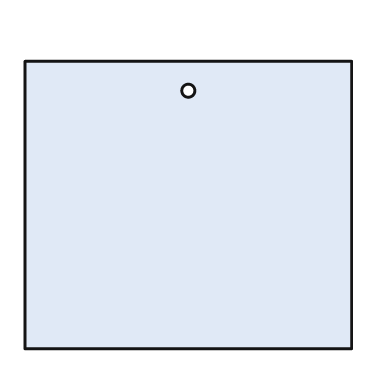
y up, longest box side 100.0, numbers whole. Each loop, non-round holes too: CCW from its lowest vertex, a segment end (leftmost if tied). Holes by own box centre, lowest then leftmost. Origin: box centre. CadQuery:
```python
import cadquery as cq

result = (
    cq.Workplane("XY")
    .moveTo(-50.0, -44.0)
    .lineTo(50.0, -44.0)
    .lineTo(50.0, 44.0)
    .lineTo(-50.0, 44.0)
    .close()
    .moveTo(0.0, 35.0)
    .circle(2.0)
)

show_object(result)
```